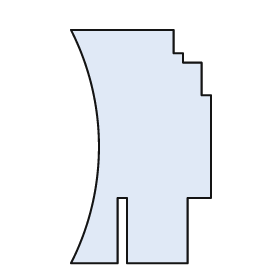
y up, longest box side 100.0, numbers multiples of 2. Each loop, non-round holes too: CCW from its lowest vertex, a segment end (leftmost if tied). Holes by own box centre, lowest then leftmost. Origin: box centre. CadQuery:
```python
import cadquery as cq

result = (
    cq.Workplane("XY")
    .moveTo(-30.0, -50.0)
    .lineTo(-10.0, -50.0)
    .lineTo(-10.0, -22.0)
    .lineTo(-6.0, -22.0)
    .lineTo(-6.0, -50.0)
    .lineTo(20.0, -50.0)
    .lineTo(20.0, -22.0)
    .lineTo(30.0, -22.0)
    .lineTo(30.0, 22.0)
    .lineTo(26.0, 22.0)
    .lineTo(26.0, 36.0)
    .lineTo(18.0, 36.0)
    .lineTo(18.0, 40.0)
    .lineTo(14.0, 40.0)
    .lineTo(14.0, 50.0)
    .lineTo(-30.0, 50.0)
    .threePointArc((-18.0, 0.0), (-30.0, -50.0))
    .close()
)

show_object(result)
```